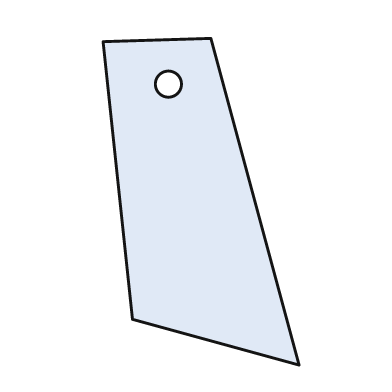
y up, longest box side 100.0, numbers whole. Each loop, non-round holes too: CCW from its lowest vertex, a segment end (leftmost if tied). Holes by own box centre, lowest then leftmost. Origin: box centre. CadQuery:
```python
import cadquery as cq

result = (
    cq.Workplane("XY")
    .moveTo(30.0, -50.0)
    .lineTo(3.0, 50.0)
    .lineTo(-30.0, 49.0)
    .lineTo(-21.0, -36.0)
    .close()
    .moveTo(-10.0, 36.0)
    .circle(4.0)
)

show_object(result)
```